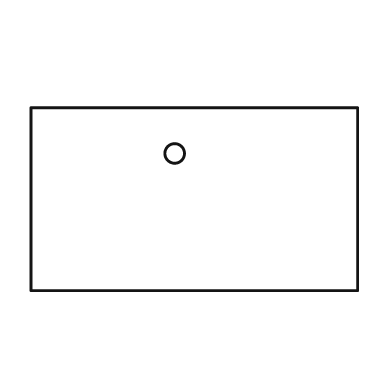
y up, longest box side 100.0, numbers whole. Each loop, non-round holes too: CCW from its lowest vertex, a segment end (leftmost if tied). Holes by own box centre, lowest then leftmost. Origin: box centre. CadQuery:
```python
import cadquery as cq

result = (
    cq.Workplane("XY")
    .moveTo(-50.0, -28.0)
    .lineTo(50.0, -28.0)
    .lineTo(50.0, 28.0)
    .lineTo(-50.0, 28.0)
    .close()
    .moveTo(-6.0, 14.0)
    .circle(3.0)
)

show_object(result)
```